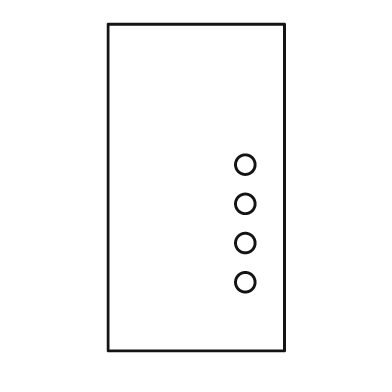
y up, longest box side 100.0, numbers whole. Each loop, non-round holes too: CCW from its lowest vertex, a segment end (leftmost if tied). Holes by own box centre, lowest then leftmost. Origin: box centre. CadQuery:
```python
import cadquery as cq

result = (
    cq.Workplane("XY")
    .moveTo(-27.0, -50.0)
    .lineTo(27.0, -50.0)
    .lineTo(27.0, 50.0)
    .lineTo(-27.0, 50.0)
    .close()
    .moveTo(15.0, -29.0)
    .circle(3.0)
    .moveTo(15.0, -17.0)
    .circle(3.0)
    .moveTo(15.0, -5.0)
    .circle(3.0)
    .moveTo(15.0, 7.0)
    .circle(3.0)
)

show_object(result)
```